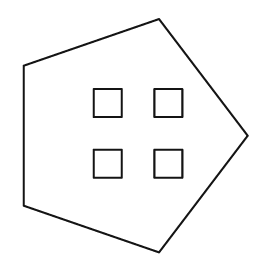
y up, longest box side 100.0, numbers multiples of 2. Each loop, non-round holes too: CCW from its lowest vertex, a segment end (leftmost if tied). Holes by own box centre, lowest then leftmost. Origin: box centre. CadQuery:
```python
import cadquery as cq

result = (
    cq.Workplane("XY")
    .moveTo(10.0, -50.0)
    .lineTo(48.0, 0.0)
    .lineTo(10.0, 50.0)
    .lineTo(-48.0, 30.0)
    .lineTo(-48.0, -30.0)
    .close()
    .moveTo(-18.0, -18.0)
    .lineTo(-6.0, -18.0)
    .lineTo(-6.0, -6.0)
    .lineTo(-18.0, -6.0)
    .close()
    .moveTo(8.0, -18.0)
    .lineTo(20.0, -18.0)
    .lineTo(20.0, -6.0)
    .lineTo(8.0, -6.0)
    .close()
    .moveTo(-18.0, 8.0)
    .lineTo(-6.0, 8.0)
    .lineTo(-6.0, 20.0)
    .lineTo(-18.0, 20.0)
    .close()
    .moveTo(8.0, 8.0)
    .lineTo(20.0, 8.0)
    .lineTo(20.0, 20.0)
    .lineTo(8.0, 20.0)
    .close()
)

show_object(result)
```